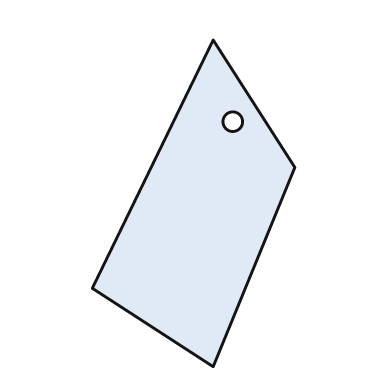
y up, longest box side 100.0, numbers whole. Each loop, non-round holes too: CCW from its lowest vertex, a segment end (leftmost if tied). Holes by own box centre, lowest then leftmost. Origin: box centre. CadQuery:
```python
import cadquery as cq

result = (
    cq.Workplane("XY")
    .moveTo(6.0, -50.0)
    .lineTo(31.0, 11.0)
    .lineTo(6.0, 50.0)
    .lineTo(-31.0, -26.0)
    .close()
    .moveTo(12.0, 25.0)
    .circle(3.0)
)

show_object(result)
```